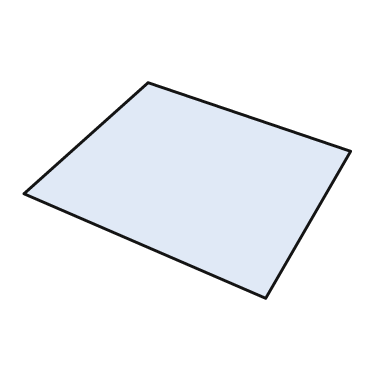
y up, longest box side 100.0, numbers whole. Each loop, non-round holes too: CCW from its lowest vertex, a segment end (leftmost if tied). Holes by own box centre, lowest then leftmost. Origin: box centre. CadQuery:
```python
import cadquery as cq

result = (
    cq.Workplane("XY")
    .moveTo(24.0, -33.0)
    .lineTo(50.0, 12.0)
    .lineTo(-12.0, 33.0)
    .lineTo(-50.0, -1.0)
    .close()
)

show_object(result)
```